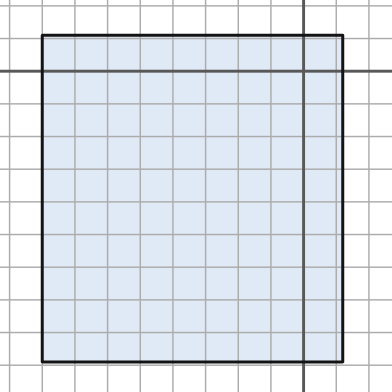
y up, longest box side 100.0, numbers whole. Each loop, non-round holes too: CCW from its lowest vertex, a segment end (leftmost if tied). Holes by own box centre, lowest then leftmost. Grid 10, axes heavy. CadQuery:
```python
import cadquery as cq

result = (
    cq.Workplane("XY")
    .moveTo(-80.0, -89.0)
    .lineTo(12.0, -89.0)
    .lineTo(12.0, 11.0)
    .lineTo(-80.0, 11.0)
    .close()
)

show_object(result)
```